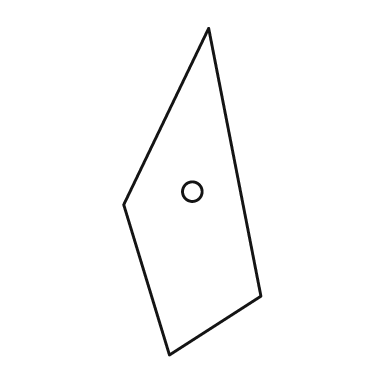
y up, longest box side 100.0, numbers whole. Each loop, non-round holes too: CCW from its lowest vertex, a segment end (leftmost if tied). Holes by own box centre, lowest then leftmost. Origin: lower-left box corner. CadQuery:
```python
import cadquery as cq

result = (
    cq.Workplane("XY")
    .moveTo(14.0, 0.0)
    .lineTo(42.0, 18.0)
    .lineTo(26.0, 100.0)
    .lineTo(0.0, 46.0)
    .close()
    .moveTo(21.0, 50.0)
    .circle(3.0)
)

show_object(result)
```